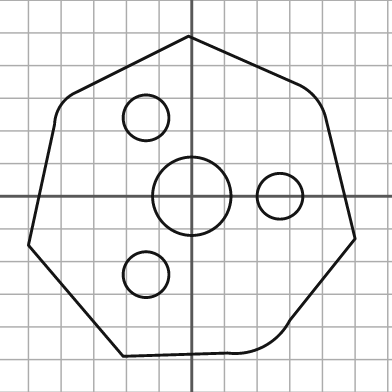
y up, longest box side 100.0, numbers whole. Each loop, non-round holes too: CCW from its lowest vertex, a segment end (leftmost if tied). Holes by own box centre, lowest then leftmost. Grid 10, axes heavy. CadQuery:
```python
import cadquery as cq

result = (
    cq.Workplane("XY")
    .moveTo(-21.0, -49.0)
    .lineTo(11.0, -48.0)
    .threePointArc((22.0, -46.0), (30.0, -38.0))
    .lineTo(50.0, -13.0)
    .lineTo(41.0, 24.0)
    .threePointArc((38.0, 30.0), (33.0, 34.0))
    .lineTo(-1.0, 49.0)
    .lineTo(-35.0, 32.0)
    .threePointArc((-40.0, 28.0), (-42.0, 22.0))
    .lineTo(-50.0, -15.0)
    .close()
    .moveTo(-14.0, -24.0)
    .circle(7.0)
    .moveTo(0.0, 0.0)
    .circle(12.0)
    .moveTo(27.0, 0.0)
    .circle(7.0)
    .moveTo(-14.0, 24.0)
    .circle(7.0)
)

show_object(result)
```